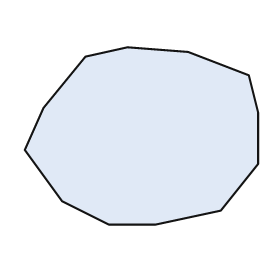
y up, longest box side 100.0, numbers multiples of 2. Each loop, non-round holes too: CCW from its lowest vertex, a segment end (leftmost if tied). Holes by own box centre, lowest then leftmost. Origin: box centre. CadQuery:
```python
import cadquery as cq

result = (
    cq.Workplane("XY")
    .moveTo(-14.0, -38.0)
    .lineTo(6.0, -38.0)
    .lineTo(34.0, -32.0)
    .lineTo(50.0, -12.0)
    .lineTo(50.0, 10.0)
    .lineTo(46.0, 26.0)
    .lineTo(20.0, 36.0)
    .lineTo(-6.0, 38.0)
    .lineTo(-24.0, 34.0)
    .lineTo(-42.0, 12.0)
    .lineTo(-50.0, -6.0)
    .lineTo(-34.0, -28.0)
    .close()
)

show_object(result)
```